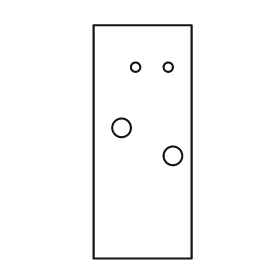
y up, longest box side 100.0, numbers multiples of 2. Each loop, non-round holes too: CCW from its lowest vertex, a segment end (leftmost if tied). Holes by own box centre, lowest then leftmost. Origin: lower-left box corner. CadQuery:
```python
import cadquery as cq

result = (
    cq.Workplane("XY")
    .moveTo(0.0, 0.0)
    .lineTo(42.0, 0.0)
    .lineTo(42.0, 100.0)
    .lineTo(0.0, 100.0)
    .close()
    .moveTo(34.0, 44.0)
    .circle(4.0)
    .moveTo(12.0, 56.0)
    .circle(4.0)
    .moveTo(18.0, 82.0)
    .circle(2.0)
    .moveTo(32.0, 82.0)
    .circle(2.0)
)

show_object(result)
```